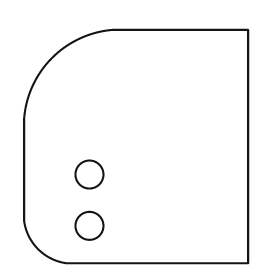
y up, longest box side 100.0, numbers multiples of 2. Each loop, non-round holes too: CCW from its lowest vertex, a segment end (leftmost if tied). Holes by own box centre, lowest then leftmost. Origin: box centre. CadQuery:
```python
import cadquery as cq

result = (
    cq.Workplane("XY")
    .moveTo(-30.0, -50.0)
    .lineTo(48.0, -50.0)
    .lineTo(48.0, 50.0)
    .lineTo(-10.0, 50.0)
    .threePointArc((-36.0, 38.0), (-48.0, 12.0))
    .lineTo(-48.0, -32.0)
    .threePointArc((-42.0, -44.0), (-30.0, -50.0))
    .close()
    .moveTo(-20.0, -34.0)
    .circle(6.0)
    .moveTo(-20.0, -12.0)
    .circle(6.0)
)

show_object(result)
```